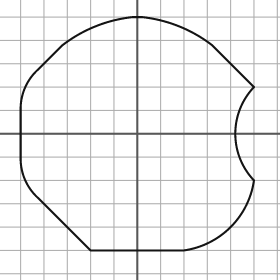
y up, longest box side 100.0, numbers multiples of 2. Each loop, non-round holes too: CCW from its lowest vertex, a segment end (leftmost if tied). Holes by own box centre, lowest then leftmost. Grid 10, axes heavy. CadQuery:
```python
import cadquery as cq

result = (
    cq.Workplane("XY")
    .moveTo(-20.0, -50.0)
    .lineTo(20.0, -50.0)
    .threePointArc((40.0, -40.0), (50.0, -20.0))
    .threePointArc((42.0, 0.0), (50.0, 20.0))
    .lineTo(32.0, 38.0)
    .threePointArc((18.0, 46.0), (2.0, 50.0))
    .lineTo(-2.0, 50.0)
    .threePointArc((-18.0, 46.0), (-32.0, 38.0))
    .lineTo(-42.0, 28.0)
    .threePointArc((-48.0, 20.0), (-50.0, 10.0))
    .lineTo(-50.0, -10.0)
    .threePointArc((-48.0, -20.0), (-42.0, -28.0))
    .close()
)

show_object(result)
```